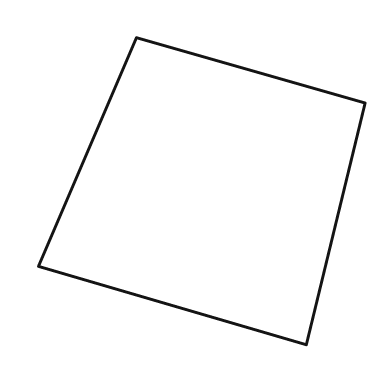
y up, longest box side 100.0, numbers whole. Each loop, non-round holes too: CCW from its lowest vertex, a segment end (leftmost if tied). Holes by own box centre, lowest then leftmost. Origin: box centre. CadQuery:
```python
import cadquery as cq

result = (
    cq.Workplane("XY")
    .moveTo(32.0, -47.0)
    .lineTo(50.0, 27.0)
    .lineTo(-20.0, 47.0)
    .lineTo(-50.0, -23.0)
    .close()
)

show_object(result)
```